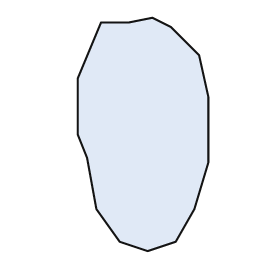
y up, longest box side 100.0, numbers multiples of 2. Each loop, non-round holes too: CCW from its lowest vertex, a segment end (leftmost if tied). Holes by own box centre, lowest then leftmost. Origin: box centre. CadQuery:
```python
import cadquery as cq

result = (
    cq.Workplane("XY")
    .moveTo(2.0, -50.0)
    .lineTo(14.0, -46.0)
    .lineTo(22.0, -32.0)
    .lineTo(28.0, -12.0)
    .lineTo(28.0, 16.0)
    .lineTo(24.0, 34.0)
    .lineTo(12.0, 46.0)
    .lineTo(4.0, 50.0)
    .lineTo(-6.0, 48.0)
    .lineTo(-18.0, 48.0)
    .lineTo(-28.0, 24.0)
    .lineTo(-28.0, 0.0)
    .lineTo(-24.0, -10.0)
    .lineTo(-20.0, -32.0)
    .lineTo(-10.0, -46.0)
    .close()
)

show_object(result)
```